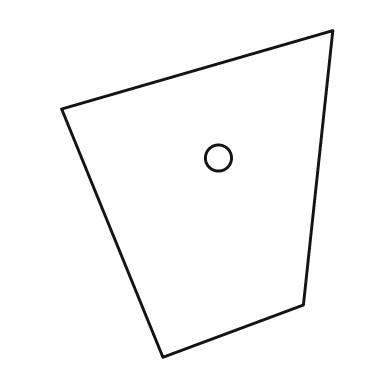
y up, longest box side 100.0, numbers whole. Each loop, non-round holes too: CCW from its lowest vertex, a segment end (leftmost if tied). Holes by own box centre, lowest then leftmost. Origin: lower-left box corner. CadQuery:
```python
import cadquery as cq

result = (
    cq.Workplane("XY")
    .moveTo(31.0, 0.0)
    .lineTo(74.0, 16.0)
    .lineTo(83.0, 100.0)
    .lineTo(0.0, 76.0)
    .close()
    .moveTo(48.0, 61.0)
    .circle(4.0)
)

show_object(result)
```